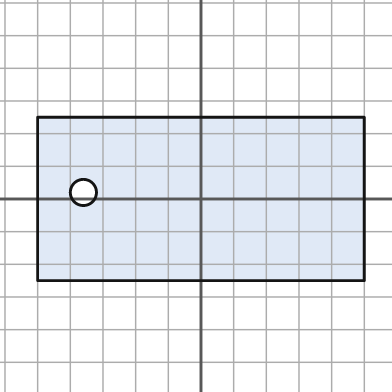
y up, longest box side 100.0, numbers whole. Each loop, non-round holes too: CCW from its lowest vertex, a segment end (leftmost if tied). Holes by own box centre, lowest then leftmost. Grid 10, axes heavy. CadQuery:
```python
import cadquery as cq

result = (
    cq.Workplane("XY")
    .moveTo(-50.0, -25.0)
    .lineTo(50.0, -25.0)
    .lineTo(50.0, 25.0)
    .lineTo(-50.0, 25.0)
    .close()
    .moveTo(-36.0, 2.0)
    .circle(4.0)
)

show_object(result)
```